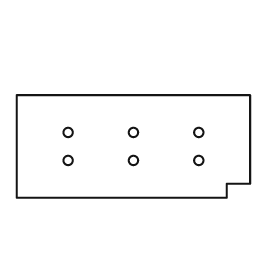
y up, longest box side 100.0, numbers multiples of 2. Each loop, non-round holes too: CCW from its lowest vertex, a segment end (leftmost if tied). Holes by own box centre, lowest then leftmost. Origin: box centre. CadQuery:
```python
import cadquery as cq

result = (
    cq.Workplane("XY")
    .moveTo(-50.0, -22.0)
    .lineTo(40.0, -22.0)
    .lineTo(40.0, -16.0)
    .lineTo(50.0, -16.0)
    .lineTo(50.0, 22.0)
    .lineTo(-50.0, 22.0)
    .close()
    .moveTo(-28.0, -6.0)
    .circle(2.0)
    .moveTo(0.0, -6.0)
    .circle(2.0)
    .moveTo(28.0, -6.0)
    .circle(2.0)
    .moveTo(-28.0, 6.0)
    .circle(2.0)
    .moveTo(0.0, 6.0)
    .circle(2.0)
    .moveTo(28.0, 6.0)
    .circle(2.0)
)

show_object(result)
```